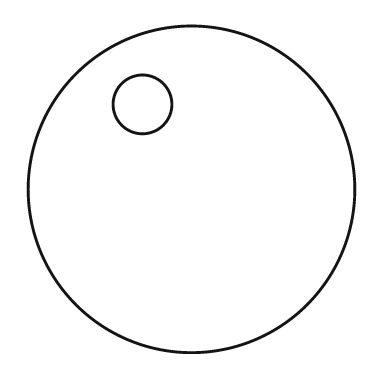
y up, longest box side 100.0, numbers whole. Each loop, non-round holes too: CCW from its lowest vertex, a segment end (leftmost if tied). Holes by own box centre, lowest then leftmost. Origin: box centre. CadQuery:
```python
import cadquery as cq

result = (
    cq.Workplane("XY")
    .moveTo(0.0, 0.0)
    .circle(50.0)
    .moveTo(-15.0, 26.0)
    .circle(9.0)
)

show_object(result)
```